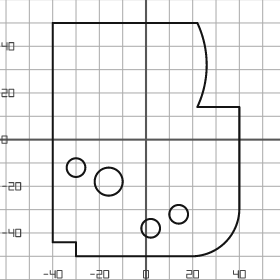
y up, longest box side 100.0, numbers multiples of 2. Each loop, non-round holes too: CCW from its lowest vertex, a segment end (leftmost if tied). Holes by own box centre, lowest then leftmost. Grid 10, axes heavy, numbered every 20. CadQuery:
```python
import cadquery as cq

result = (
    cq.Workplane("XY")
    .moveTo(-30.0, -50.0)
    .lineTo(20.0, -50.0)
    .threePointArc((34.0, -44.0), (40.0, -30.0))
    .lineTo(40.0, 14.0)
    .lineTo(22.0, 14.0)
    .threePointArc((26.0, 32.0), (22.0, 50.0))
    .lineTo(-40.0, 50.0)
    .lineTo(-40.0, -44.0)
    .lineTo(-30.0, -44.0)
    .close()
    .moveTo(2.0, -38.0)
    .circle(4.0)
    .moveTo(14.0, -32.0)
    .circle(4.0)
    .moveTo(-16.0, -18.0)
    .circle(6.0)
    .moveTo(-30.0, -12.0)
    .circle(4.0)
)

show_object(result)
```